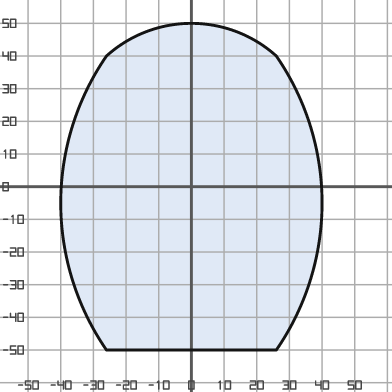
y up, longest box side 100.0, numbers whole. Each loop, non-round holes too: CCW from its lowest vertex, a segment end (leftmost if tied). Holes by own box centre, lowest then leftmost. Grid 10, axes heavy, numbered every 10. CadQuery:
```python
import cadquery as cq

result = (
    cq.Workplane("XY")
    .moveTo(-26.0, -50.0)
    .lineTo(26.0, -50.0)
    .threePointArc((40.0, -5.0), (26.0, 40.0))
    .threePointArc((0.0, 50.0), (-26.0, 40.0))
    .threePointArc((-40.0, -5.0), (-26.0, -50.0))
    .close()
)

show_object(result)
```